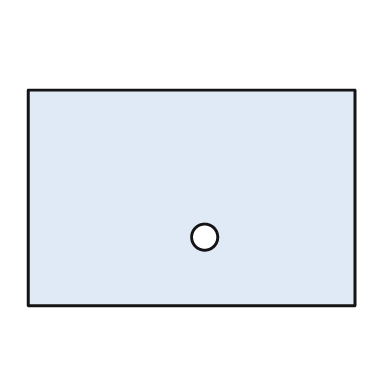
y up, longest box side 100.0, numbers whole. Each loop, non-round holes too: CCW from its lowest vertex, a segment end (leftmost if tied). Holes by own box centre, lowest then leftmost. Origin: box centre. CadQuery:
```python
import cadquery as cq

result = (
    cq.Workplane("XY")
    .moveTo(-50.0, -33.0)
    .lineTo(50.0, -33.0)
    .lineTo(50.0, 33.0)
    .lineTo(-50.0, 33.0)
    .close()
    .moveTo(4.0, -12.0)
    .circle(4.0)
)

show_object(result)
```